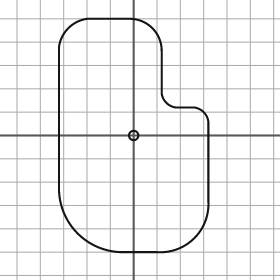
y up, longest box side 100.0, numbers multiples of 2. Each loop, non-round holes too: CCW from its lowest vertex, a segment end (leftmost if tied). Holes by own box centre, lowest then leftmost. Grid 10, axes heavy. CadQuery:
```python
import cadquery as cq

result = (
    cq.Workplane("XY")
    .moveTo(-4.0, -50.0)
    .lineTo(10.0, -50.0)
    .threePointArc((26.0, -44.0), (32.0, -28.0))
    .lineTo(32.0, 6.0)
    .threePointArc((30.0, 10.0), (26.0, 12.0))
    .lineTo(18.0, 12.0)
    .threePointArc((14.0, 14.0), (12.0, 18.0))
    .lineTo(12.0, 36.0)
    .threePointArc((8.0, 46.0), (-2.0, 50.0))
    .lineTo(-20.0, 50.0)
    .threePointArc((-28.0, 46.0), (-32.0, 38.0))
    .lineTo(-32.0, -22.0)
    .threePointArc((-24.0, -42.0), (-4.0, -50.0))
    .close()
    .moveTo(0.0, 0.0)
    .circle(2.0)
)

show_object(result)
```